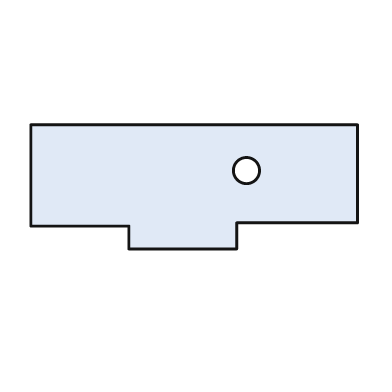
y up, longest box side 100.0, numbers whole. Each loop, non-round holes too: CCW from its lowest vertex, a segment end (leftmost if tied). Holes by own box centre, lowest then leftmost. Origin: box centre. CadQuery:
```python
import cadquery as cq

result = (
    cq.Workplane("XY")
    .moveTo(-20.0, -19.0)
    .lineTo(13.0, -19.0)
    .lineTo(13.0, -11.0)
    .lineTo(50.0, -11.0)
    .lineTo(50.0, 19.0)
    .lineTo(-50.0, 19.0)
    .lineTo(-50.0, -12.0)
    .lineTo(-20.0, -12.0)
    .close()
    .moveTo(16.0, 5.0)
    .circle(4.0)
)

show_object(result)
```